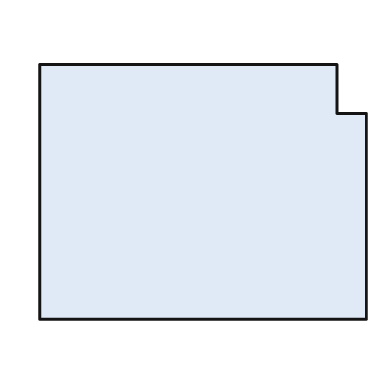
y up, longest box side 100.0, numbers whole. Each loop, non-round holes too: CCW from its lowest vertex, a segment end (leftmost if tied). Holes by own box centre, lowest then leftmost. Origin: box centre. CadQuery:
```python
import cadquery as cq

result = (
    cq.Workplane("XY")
    .moveTo(-50.0, -39.0)
    .lineTo(50.0, -39.0)
    .lineTo(50.0, 24.0)
    .lineTo(41.0, 24.0)
    .lineTo(41.0, 39.0)
    .lineTo(-50.0, 39.0)
    .close()
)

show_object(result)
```